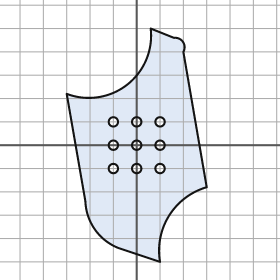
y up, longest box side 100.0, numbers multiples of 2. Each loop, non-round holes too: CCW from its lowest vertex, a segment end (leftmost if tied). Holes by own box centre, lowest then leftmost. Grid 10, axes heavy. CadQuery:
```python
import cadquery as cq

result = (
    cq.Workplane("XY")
    .moveTo(10.0, -50.0)
    .threePointArc((14.0, -30.0), (30.0, -18.0))
    .lineTo(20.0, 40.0)
    .threePointArc((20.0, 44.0), (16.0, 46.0))
    .lineTo(6.0, 50.0)
    .threePointArc((-4.0, 26.0), (-30.0, 22.0))
    .lineTo(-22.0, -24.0)
    .threePointArc((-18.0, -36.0), (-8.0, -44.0))
    .close()
    .moveTo(-10.0, -10.0)
    .circle(2.0)
    .moveTo(0.0, -10.0)
    .circle(2.0)
    .moveTo(10.0, -10.0)
    .circle(2.0)
    .moveTo(-10.0, 0.0)
    .circle(2.0)
    .moveTo(0.0, 0.0)
    .circle(2.0)
    .moveTo(10.0, 0.0)
    .circle(2.0)
    .moveTo(-10.0, 10.0)
    .circle(2.0)
    .moveTo(0.0, 10.0)
    .circle(2.0)
    .moveTo(10.0, 10.0)
    .circle(2.0)
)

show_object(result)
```